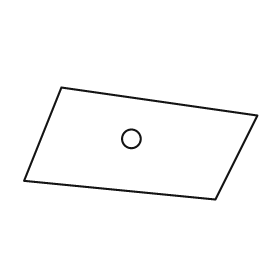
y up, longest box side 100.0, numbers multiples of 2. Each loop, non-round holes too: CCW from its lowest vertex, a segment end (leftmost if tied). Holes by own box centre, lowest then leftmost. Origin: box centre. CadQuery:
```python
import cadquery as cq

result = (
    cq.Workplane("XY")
    .moveTo(32.0, -24.0)
    .lineTo(50.0, 12.0)
    .lineTo(-34.0, 24.0)
    .lineTo(-50.0, -16.0)
    .close()
    .moveTo(-4.0, 2.0)
    .circle(4.0)
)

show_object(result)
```